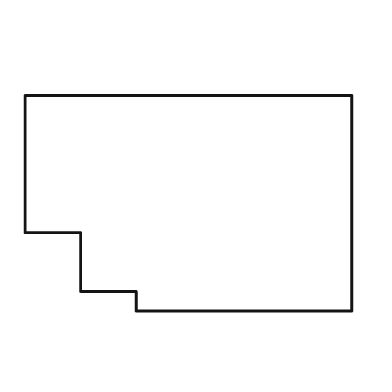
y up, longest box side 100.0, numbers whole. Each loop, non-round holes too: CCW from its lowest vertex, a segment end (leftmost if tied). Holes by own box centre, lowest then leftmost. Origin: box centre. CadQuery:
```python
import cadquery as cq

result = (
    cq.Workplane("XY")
    .moveTo(-16.0, -33.0)
    .lineTo(50.0, -33.0)
    .lineTo(50.0, 33.0)
    .lineTo(-50.0, 33.0)
    .lineTo(-50.0, -9.0)
    .lineTo(-33.0, -9.0)
    .lineTo(-33.0, -27.0)
    .lineTo(-16.0, -27.0)
    .close()
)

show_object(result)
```